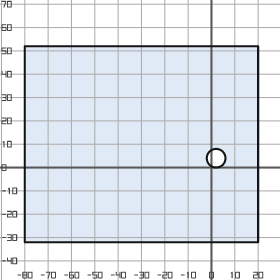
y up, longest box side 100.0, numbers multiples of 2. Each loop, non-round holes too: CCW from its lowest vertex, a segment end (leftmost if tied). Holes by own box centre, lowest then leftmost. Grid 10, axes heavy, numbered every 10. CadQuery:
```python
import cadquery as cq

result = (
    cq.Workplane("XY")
    .moveTo(-80.0, -32.0)
    .lineTo(20.0, -32.0)
    .lineTo(20.0, 52.0)
    .lineTo(-80.0, 52.0)
    .close()
    .moveTo(2.0, 4.0)
    .circle(4.0)
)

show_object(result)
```